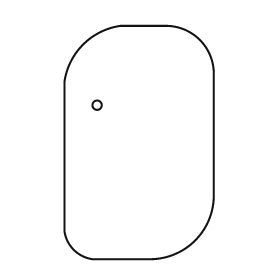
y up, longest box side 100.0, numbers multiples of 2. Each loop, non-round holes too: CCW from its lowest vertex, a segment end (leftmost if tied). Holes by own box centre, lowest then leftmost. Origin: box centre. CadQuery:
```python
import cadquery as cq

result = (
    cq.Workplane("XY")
    .moveTo(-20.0, -50.0)
    .lineTo(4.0, -50.0)
    .threePointArc((24.0, -42.0), (32.0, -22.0))
    .lineTo(32.0, 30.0)
    .threePointArc((26.0, 44.0), (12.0, 50.0))
    .lineTo(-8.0, 50.0)
    .threePointArc((-24.0, 42.0), (-32.0, 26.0))
    .lineTo(-32.0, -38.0)
    .threePointArc((-28.0, -46.0), (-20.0, -50.0))
    .close()
    .moveTo(-18.0, 16.0)
    .circle(2.0)
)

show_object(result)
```